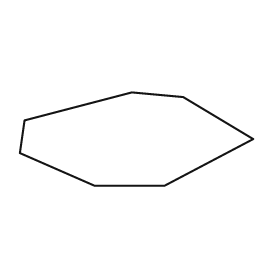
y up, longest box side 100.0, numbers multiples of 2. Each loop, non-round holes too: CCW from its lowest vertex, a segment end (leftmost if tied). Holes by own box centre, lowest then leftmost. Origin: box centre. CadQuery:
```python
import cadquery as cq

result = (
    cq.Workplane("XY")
    .moveTo(-18.0, -20.0)
    .lineTo(12.0, -20.0)
    .lineTo(50.0, 0.0)
    .lineTo(20.0, 18.0)
    .lineTo(-2.0, 20.0)
    .lineTo(-48.0, 8.0)
    .lineTo(-50.0, -6.0)
    .close()
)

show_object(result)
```